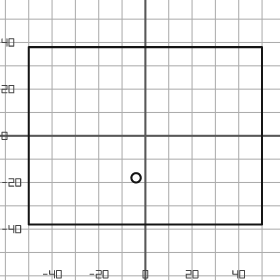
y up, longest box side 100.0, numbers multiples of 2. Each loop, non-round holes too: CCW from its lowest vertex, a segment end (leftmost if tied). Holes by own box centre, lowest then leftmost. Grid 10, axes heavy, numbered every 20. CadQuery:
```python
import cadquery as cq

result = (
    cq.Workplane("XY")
    .moveTo(-50.0, -38.0)
    .lineTo(50.0, -38.0)
    .lineTo(50.0, 38.0)
    .lineTo(-50.0, 38.0)
    .close()
    .moveTo(-4.0, -18.0)
    .circle(2.0)
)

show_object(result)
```